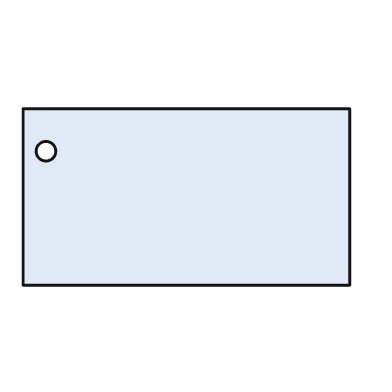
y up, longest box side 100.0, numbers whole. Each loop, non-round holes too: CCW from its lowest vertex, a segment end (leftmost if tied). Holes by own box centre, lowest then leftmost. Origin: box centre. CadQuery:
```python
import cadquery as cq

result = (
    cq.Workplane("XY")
    .moveTo(-50.0, -27.0)
    .lineTo(50.0, -27.0)
    .lineTo(50.0, 27.0)
    .lineTo(-50.0, 27.0)
    .close()
    .moveTo(-43.0, 14.0)
    .circle(3.0)
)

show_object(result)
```